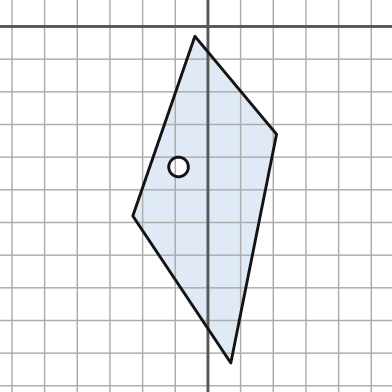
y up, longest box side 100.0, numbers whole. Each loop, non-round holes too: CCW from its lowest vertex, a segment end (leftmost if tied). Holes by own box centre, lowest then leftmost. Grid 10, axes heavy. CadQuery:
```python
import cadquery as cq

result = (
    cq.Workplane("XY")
    .moveTo(7.0, -103.0)
    .lineTo(21.0, -33.0)
    .lineTo(-4.0, -3.0)
    .lineTo(-23.0, -58.0)
    .close()
    .moveTo(-9.0, -43.0)
    .circle(3.0)
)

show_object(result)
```